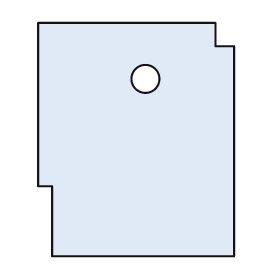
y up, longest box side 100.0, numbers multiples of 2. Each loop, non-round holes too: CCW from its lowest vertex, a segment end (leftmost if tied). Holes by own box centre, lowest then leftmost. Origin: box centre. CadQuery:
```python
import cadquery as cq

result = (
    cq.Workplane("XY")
    .moveTo(-36.0, -50.0)
    .lineTo(42.0, -50.0)
    .lineTo(42.0, 40.0)
    .lineTo(34.0, 40.0)
    .lineTo(34.0, 50.0)
    .lineTo(-42.0, 50.0)
    .lineTo(-42.0, -20.0)
    .lineTo(-36.0, -20.0)
    .close()
    .moveTo(4.0, 26.0)
    .circle(6.0)
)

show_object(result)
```